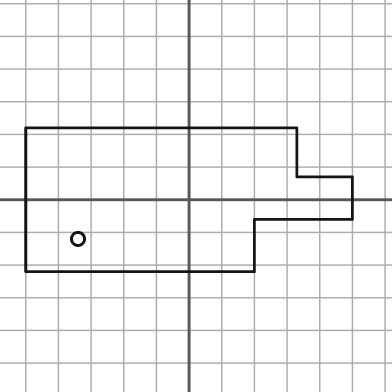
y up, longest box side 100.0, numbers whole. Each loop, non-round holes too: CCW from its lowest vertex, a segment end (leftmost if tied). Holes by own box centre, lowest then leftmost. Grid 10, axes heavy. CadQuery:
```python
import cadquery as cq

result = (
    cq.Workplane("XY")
    .moveTo(-50.0, -22.0)
    .lineTo(20.0, -22.0)
    .lineTo(20.0, -6.0)
    .lineTo(50.0, -6.0)
    .lineTo(50.0, 7.0)
    .lineTo(33.0, 7.0)
    .lineTo(33.0, 22.0)
    .lineTo(-50.0, 22.0)
    .close()
    .moveTo(-34.0, -12.0)
    .circle(2.0)
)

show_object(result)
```